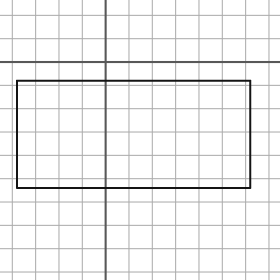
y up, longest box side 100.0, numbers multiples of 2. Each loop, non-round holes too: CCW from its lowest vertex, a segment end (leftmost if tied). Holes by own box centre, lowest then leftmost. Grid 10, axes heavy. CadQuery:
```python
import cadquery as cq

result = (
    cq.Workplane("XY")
    .moveTo(-38.0, -54.0)
    .lineTo(62.0, -54.0)
    .lineTo(62.0, -8.0)
    .lineTo(-38.0, -8.0)
    .close()
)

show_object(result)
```